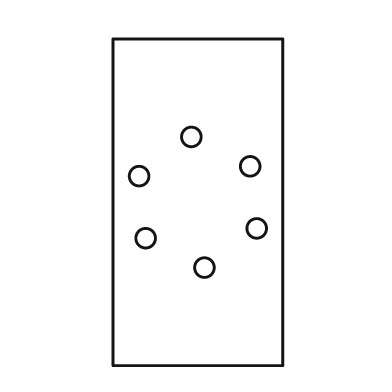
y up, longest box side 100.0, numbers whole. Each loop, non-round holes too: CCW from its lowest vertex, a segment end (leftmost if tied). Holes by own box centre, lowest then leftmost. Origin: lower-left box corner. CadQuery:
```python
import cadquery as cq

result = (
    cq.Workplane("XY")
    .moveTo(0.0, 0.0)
    .lineTo(52.0, 0.0)
    .lineTo(52.0, 100.0)
    .lineTo(0.0, 100.0)
    .close()
    .moveTo(28.0, 30.0)
    .circle(3.0)
    .moveTo(10.0, 39.0)
    .circle(3.0)
    .moveTo(44.0, 42.0)
    .circle(3.0)
    .moveTo(8.0, 58.0)
    .circle(3.0)
    .moveTo(42.0, 61.0)
    .circle(3.0)
    .moveTo(24.0, 70.0)
    .circle(3.0)
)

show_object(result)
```